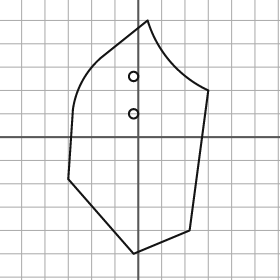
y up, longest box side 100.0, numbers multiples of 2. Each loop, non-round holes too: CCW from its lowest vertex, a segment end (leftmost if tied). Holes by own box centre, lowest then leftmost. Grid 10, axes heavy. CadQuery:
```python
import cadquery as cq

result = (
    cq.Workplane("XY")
    .moveTo(-2.0, -50.0)
    .lineTo(22.0, -40.0)
    .lineTo(30.0, 20.0)
    .threePointArc((14.0, 32.0), (4.0, 50.0))
    .lineTo(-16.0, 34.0)
    .threePointArc((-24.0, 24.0), (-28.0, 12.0))
    .lineTo(-30.0, -18.0)
    .close()
    .moveTo(-2.0, 10.0)
    .circle(2.0)
    .moveTo(-2.0, 26.0)
    .circle(2.0)
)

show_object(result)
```